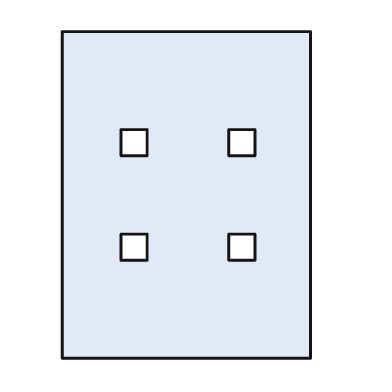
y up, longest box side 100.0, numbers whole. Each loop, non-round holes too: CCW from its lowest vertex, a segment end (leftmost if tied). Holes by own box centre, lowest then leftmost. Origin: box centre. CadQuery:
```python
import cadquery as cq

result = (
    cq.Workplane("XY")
    .moveTo(-38.0, -50.0)
    .lineTo(38.0, -50.0)
    .lineTo(38.0, 50.0)
    .lineTo(-38.0, 50.0)
    .close()
    .moveTo(-20.0, -20.0)
    .lineTo(-12.0, -20.0)
    .lineTo(-12.0, -12.0)
    .lineTo(-20.0, -12.0)
    .close()
    .moveTo(13.0, -20.0)
    .lineTo(21.0, -20.0)
    .lineTo(21.0, -12.0)
    .lineTo(13.0, -12.0)
    .close()
    .moveTo(-20.0, 12.0)
    .lineTo(-12.0, 12.0)
    .lineTo(-12.0, 20.0)
    .lineTo(-20.0, 20.0)
    .close()
    .moveTo(13.0, 12.0)
    .lineTo(21.0, 12.0)
    .lineTo(21.0, 20.0)
    .lineTo(13.0, 20.0)
    .close()
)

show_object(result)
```